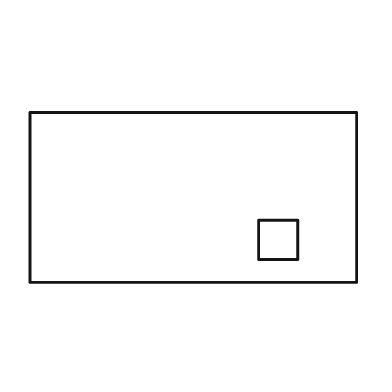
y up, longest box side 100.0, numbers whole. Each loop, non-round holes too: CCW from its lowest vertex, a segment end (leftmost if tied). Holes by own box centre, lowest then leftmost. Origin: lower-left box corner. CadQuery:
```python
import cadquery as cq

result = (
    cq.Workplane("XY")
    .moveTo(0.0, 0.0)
    .lineTo(100.0, 0.0)
    .lineTo(100.0, 52.0)
    .lineTo(0.0, 52.0)
    .close()
    .moveTo(70.0, 7.0)
    .lineTo(82.0, 7.0)
    .lineTo(82.0, 19.0)
    .lineTo(70.0, 19.0)
    .close()
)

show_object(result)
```